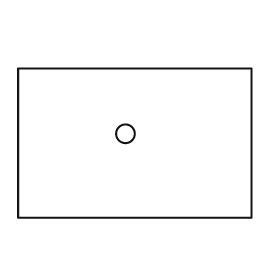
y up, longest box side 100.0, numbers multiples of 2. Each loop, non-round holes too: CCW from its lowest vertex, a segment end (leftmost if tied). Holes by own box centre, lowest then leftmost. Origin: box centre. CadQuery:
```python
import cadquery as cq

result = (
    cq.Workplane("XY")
    .moveTo(-50.0, -32.0)
    .lineTo(50.0, -32.0)
    .lineTo(50.0, 32.0)
    .lineTo(-50.0, 32.0)
    .close()
    .moveTo(-4.0, 4.0)
    .circle(4.0)
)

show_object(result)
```